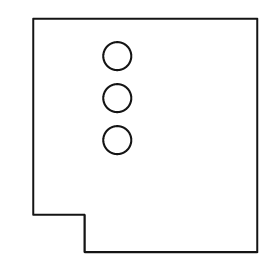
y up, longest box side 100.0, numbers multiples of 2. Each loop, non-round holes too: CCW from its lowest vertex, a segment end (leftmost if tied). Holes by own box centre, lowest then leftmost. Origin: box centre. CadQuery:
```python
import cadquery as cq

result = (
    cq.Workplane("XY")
    .moveTo(-26.0, -50.0)
    .lineTo(48.0, -50.0)
    .lineTo(48.0, 50.0)
    .lineTo(-48.0, 50.0)
    .lineTo(-48.0, -34.0)
    .lineTo(-26.0, -34.0)
    .close()
    .moveTo(-12.0, -2.0)
    .circle(6.0)
    .moveTo(-12.0, 16.0)
    .circle(6.0)
    .moveTo(-12.0, 34.0)
    .circle(6.0)
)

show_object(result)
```